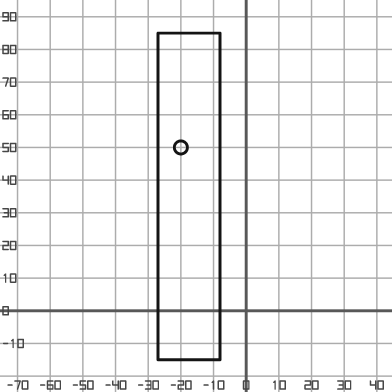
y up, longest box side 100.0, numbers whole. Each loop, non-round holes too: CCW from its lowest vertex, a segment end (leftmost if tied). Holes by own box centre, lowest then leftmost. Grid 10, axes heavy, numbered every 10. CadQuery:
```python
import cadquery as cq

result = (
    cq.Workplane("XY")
    .moveTo(-27.0, -15.0)
    .lineTo(-8.0, -15.0)
    .lineTo(-8.0, 85.0)
    .lineTo(-27.0, 85.0)
    .close()
    .moveTo(-20.0, 50.0)
    .circle(2.0)
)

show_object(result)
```